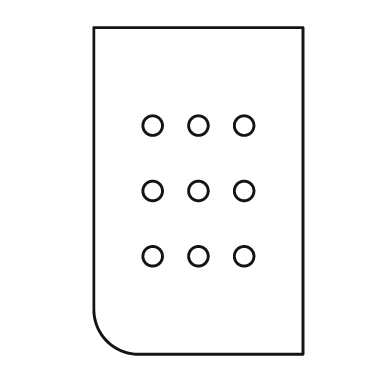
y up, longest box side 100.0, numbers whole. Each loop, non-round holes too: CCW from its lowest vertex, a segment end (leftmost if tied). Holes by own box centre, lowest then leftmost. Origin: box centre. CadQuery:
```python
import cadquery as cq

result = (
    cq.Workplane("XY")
    .moveTo(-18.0, -50.0)
    .lineTo(32.0, -50.0)
    .lineTo(32.0, 50.0)
    .lineTo(-32.0, 50.0)
    .lineTo(-32.0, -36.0)
    .threePointArc((-28.0, -46.0), (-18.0, -50.0))
    .close()
    .moveTo(-14.0, -20.0)
    .circle(3.0)
    .moveTo(0.0, -20.0)
    .circle(3.0)
    .moveTo(14.0, -20.0)
    .circle(3.0)
    .moveTo(-14.0, 0.0)
    .circle(3.0)
    .moveTo(0.0, 0.0)
    .circle(3.0)
    .moveTo(14.0, 0.0)
    .circle(3.0)
    .moveTo(-14.0, 20.0)
    .circle(3.0)
    .moveTo(0.0, 20.0)
    .circle(3.0)
    .moveTo(14.0, 20.0)
    .circle(3.0)
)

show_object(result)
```